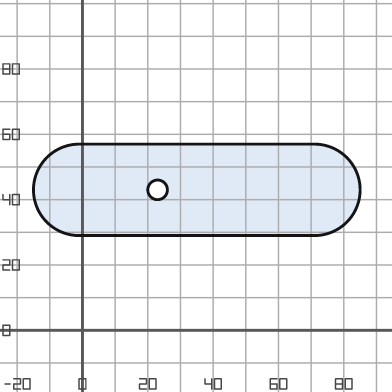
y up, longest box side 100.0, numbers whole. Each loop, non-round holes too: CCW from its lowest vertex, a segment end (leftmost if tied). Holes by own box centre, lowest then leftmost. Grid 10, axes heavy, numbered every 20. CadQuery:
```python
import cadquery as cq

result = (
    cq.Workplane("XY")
    .moveTo(-1.0, 29.0)
    .lineTo(71.0, 29.0)
    .threePointArc((85.0, 43.0), (71.0, 57.0))
    .lineTo(-1.0, 57.0)
    .threePointArc((-15.0, 43.0), (-1.0, 29.0))
    .close()
    .moveTo(23.0, 43.0)
    .circle(3.0)
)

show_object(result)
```